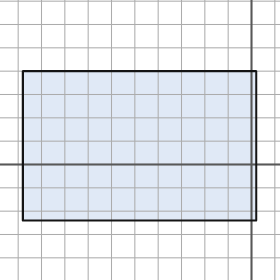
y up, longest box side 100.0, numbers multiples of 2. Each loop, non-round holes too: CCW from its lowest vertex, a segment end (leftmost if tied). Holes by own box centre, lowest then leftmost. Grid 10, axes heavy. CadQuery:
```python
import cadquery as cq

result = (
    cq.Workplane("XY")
    .moveTo(-98.0, -24.0)
    .lineTo(2.0, -24.0)
    .lineTo(2.0, 40.0)
    .lineTo(-98.0, 40.0)
    .close()
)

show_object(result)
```